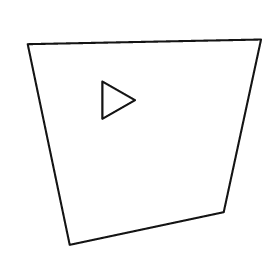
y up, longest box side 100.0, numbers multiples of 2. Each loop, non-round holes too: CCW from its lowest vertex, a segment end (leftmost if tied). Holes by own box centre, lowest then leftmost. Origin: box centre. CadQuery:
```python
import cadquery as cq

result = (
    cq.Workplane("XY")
    .moveTo(-32.0, -44.0)
    .lineTo(34.0, -30.0)
    .lineTo(50.0, 44.0)
    .lineTo(-50.0, 42.0)
    .close()
    .moveTo(-18.0, 10.0)
    .lineTo(-4.0, 18.0)
    .lineTo(-18.0, 26.0)
    .close()
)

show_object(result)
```